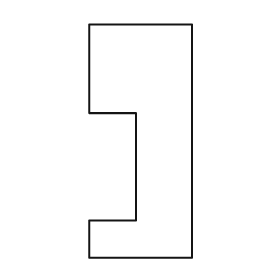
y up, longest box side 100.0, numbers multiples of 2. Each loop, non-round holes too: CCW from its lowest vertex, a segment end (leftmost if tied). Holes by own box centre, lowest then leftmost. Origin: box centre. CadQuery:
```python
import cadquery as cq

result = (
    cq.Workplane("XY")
    .moveTo(-22.0, -50.0)
    .lineTo(22.0, -50.0)
    .lineTo(22.0, 50.0)
    .lineTo(-22.0, 50.0)
    .lineTo(-22.0, 12.0)
    .lineTo(-2.0, 12.0)
    .lineTo(-2.0, -34.0)
    .lineTo(-22.0, -34.0)
    .close()
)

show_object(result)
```